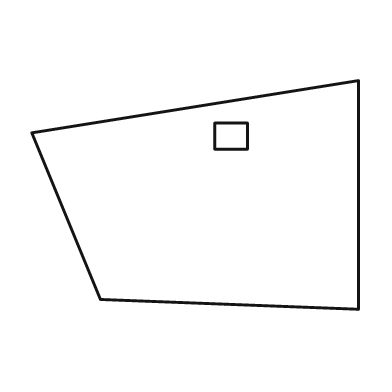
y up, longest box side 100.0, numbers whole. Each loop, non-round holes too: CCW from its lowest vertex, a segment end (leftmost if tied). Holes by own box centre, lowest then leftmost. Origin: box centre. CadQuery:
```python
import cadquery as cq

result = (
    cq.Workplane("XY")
    .moveTo(50.0, -35.0)
    .lineTo(50.0, 35.0)
    .lineTo(-50.0, 19.0)
    .lineTo(-29.0, -32.0)
    .close()
    .moveTo(6.0, 14.0)
    .lineTo(16.0, 14.0)
    .lineTo(16.0, 22.0)
    .lineTo(6.0, 22.0)
    .close()
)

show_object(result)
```